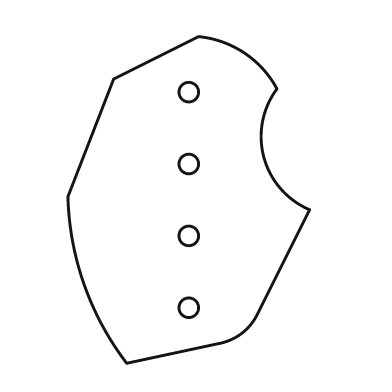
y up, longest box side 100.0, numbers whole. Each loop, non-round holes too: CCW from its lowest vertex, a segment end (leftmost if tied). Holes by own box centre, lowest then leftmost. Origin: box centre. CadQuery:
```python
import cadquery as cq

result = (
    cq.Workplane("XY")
    .moveTo(-19.0, -50.0)
    .lineTo(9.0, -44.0)
    .threePointArc((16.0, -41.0), (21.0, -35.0))
    .lineTo(37.0, -3.0)
    .threePointArc((23.0, 13.0), (27.0, 34.0))
    .threePointArc((17.0, 45.0), (3.0, 50.0))
    .lineTo(-23.0, 37.0)
    .lineTo(-37.0, 1.0)
    .threePointArc((-32.0, -26.0), (-19.0, -50.0))
    .close()
    .moveTo(0.0, -33.0)
    .circle(3.0)
    .moveTo(0.0, -11.0)
    .circle(3.0)
    .moveTo(0.0, 11.0)
    .circle(3.0)
    .moveTo(0.0, 33.0)
    .circle(3.0)
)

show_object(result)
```